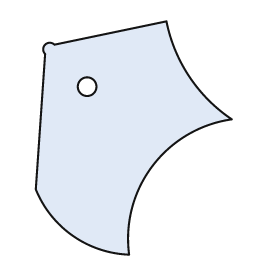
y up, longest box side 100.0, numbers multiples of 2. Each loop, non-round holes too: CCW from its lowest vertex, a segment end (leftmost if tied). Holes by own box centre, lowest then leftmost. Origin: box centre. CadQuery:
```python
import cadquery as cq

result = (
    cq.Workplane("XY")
    .moveTo(-2.0, -50.0)
    .threePointArc((8.0, -12.0), (42.0, 8.0))
    .threePointArc((24.0, 26.0), (14.0, 50.0))
    .lineTo(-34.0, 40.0)
    .threePointArc((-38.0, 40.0), (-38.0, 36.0))
    .lineTo(-42.0, -22.0)
    .threePointArc((-26.0, -42.0), (-2.0, -50.0))
    .close()
    .moveTo(-20.0, 22.0)
    .circle(4.0)
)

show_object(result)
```